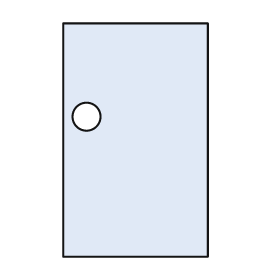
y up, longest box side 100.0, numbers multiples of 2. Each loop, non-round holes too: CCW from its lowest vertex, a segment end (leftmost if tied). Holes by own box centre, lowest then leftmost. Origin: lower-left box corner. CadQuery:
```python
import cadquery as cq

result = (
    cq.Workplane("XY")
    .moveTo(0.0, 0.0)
    .lineTo(62.0, 0.0)
    .lineTo(62.0, 100.0)
    .lineTo(0.0, 100.0)
    .close()
    .moveTo(10.0, 60.0)
    .circle(6.0)
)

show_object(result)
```